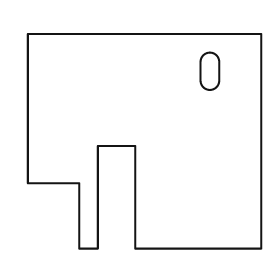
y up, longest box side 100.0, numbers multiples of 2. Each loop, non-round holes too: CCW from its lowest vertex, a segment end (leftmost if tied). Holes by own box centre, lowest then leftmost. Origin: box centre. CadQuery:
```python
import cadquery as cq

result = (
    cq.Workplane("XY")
    .moveTo(-28.0, -46.0)
    .lineTo(-20.0, -46.0)
    .lineTo(-20.0, -2.0)
    .lineTo(-4.0, -2.0)
    .lineTo(-4.0, -46.0)
    .lineTo(50.0, -46.0)
    .lineTo(50.0, 46.0)
    .lineTo(-50.0, 46.0)
    .lineTo(-50.0, -18.0)
    .lineTo(-28.0, -18.0)
    .close()
    .moveTo(24.0, 26.0)
    .threePointArc((28.0, 22.0), (32.0, 26.0))
    .lineTo(32.0, 34.0)
    .threePointArc((28.0, 38.0), (24.0, 34.0))
    .close()
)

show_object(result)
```